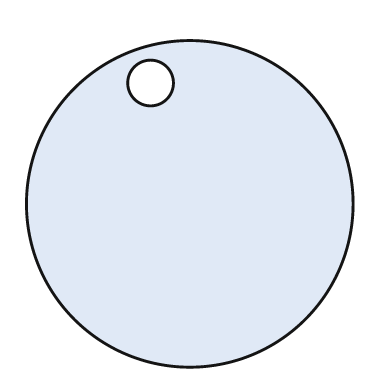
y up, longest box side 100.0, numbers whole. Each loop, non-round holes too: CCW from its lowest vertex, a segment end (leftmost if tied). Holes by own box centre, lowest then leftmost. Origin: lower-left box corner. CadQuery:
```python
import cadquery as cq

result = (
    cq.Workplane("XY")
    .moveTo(50.0, 50.0)
    .circle(50.0)
    .moveTo(38.0, 87.0)
    .circle(7.0)
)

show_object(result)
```